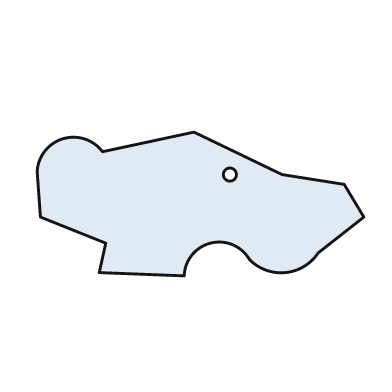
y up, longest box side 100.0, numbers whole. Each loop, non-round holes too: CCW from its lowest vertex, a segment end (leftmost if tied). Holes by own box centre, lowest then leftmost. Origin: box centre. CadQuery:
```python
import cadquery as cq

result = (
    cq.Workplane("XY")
    .moveTo(-5.0, -22.0)
    .threePointArc((3.0, -12.0), (15.0, -17.0))
    .threePointArc((26.0, -21.0), (36.0, -15.0))
    .lineTo(50.0, -4.0)
    .lineTo(44.0, 6.0)
    .lineTo(25.0, 9.0)
    .lineTo(-2.0, 22.0)
    .lineTo(-30.0, 16.0)
    .threePointArc((-42.0, 20.0), (-50.0, 10.0))
    .lineTo(-49.0, -4.0)
    .lineTo(-29.0, -12.0)
    .lineTo(-31.0, -21.0)
    .close()
    .moveTo(9.0, 9.0)
    .circle(2.0)
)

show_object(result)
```